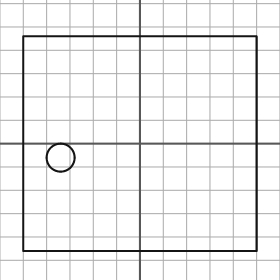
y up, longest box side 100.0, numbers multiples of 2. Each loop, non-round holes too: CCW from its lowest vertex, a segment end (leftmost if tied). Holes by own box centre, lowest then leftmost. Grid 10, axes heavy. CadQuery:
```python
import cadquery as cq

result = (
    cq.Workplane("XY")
    .moveTo(-50.0, -46.0)
    .lineTo(50.0, -46.0)
    .lineTo(50.0, 46.0)
    .lineTo(-50.0, 46.0)
    .close()
    .moveTo(-34.0, -6.0)
    .circle(6.0)
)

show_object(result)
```